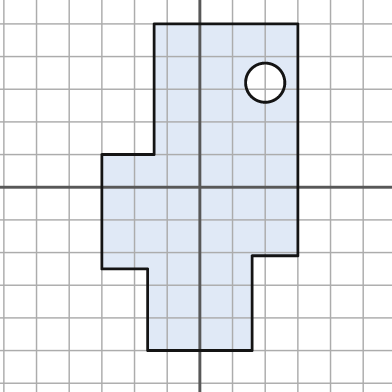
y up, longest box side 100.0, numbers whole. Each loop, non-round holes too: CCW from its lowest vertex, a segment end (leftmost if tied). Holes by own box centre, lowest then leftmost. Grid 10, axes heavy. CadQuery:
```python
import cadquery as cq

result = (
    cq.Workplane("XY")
    .moveTo(-16.0, -50.0)
    .lineTo(16.0, -50.0)
    .lineTo(16.0, -21.0)
    .lineTo(30.0, -21.0)
    .lineTo(30.0, 50.0)
    .lineTo(-14.0, 50.0)
    .lineTo(-14.0, 10.0)
    .lineTo(-30.0, 10.0)
    .lineTo(-30.0, -25.0)
    .lineTo(-16.0, -25.0)
    .close()
    .moveTo(20.0, 32.0)
    .circle(6.0)
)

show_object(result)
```